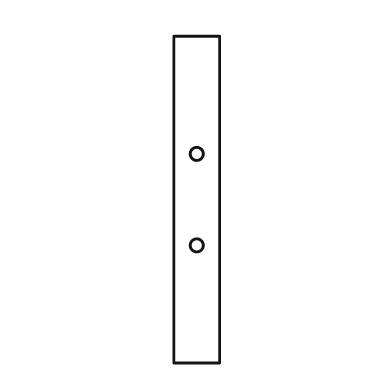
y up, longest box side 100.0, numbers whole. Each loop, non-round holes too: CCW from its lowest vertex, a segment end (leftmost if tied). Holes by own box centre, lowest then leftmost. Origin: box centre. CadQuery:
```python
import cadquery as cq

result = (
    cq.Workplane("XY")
    .moveTo(-7.0, -50.0)
    .lineTo(7.0, -50.0)
    .lineTo(7.0, 50.0)
    .lineTo(-7.0, 50.0)
    .close()
    .moveTo(0.0, -14.0)
    .circle(2.0)
    .moveTo(0.0, 14.0)
    .circle(2.0)
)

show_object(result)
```